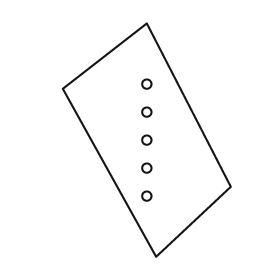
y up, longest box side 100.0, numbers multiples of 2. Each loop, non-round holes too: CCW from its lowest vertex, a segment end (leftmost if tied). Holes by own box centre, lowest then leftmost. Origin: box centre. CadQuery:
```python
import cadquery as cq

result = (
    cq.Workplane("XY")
    .moveTo(4.0, -50.0)
    .lineTo(36.0, -20.0)
    .lineTo(0.0, 50.0)
    .lineTo(-36.0, 22.0)
    .close()
    .moveTo(0.0, -24.0)
    .circle(2.0)
    .moveTo(0.0, -12.0)
    .circle(2.0)
    .moveTo(0.0, 0.0)
    .circle(2.0)
    .moveTo(0.0, 12.0)
    .circle(2.0)
    .moveTo(0.0, 24.0)
    .circle(2.0)
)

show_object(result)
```